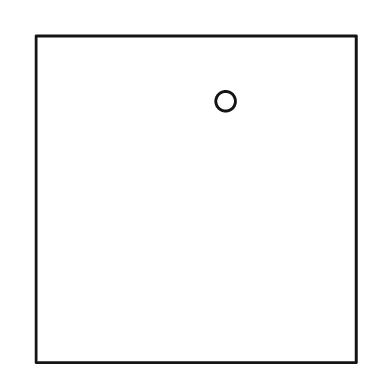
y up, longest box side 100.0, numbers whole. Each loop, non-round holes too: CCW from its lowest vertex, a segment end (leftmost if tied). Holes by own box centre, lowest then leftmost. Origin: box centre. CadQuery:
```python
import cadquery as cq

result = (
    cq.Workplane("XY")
    .moveTo(-49.0, -50.0)
    .lineTo(49.0, -50.0)
    .lineTo(49.0, 50.0)
    .lineTo(-49.0, 50.0)
    .close()
    .moveTo(9.0, 30.0)
    .circle(3.0)
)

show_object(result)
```